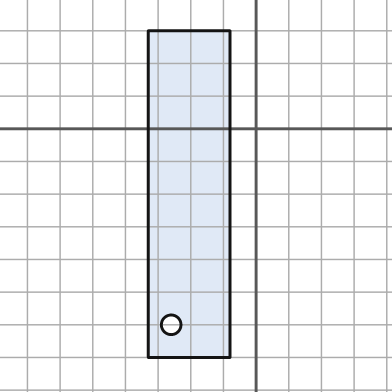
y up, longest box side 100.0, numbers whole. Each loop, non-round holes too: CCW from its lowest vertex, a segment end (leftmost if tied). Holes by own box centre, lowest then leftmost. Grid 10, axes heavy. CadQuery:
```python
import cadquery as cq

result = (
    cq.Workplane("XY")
    .moveTo(-33.0, -70.0)
    .lineTo(-8.0, -70.0)
    .lineTo(-8.0, 30.0)
    .lineTo(-33.0, 30.0)
    .close()
    .moveTo(-26.0, -60.0)
    .circle(3.0)
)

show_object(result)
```